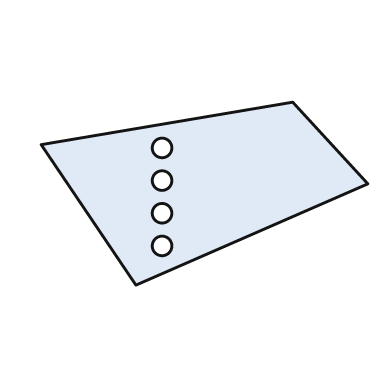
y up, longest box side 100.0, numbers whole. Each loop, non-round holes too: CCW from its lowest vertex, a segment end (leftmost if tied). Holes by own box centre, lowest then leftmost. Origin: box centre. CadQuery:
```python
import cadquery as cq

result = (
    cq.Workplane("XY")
    .moveTo(-21.0, -28.0)
    .lineTo(50.0, 3.0)
    .lineTo(27.0, 28.0)
    .lineTo(-50.0, 15.0)
    .close()
    .moveTo(-13.0, -16.0)
    .circle(3.0)
    .moveTo(-13.0, -6.0)
    .circle(3.0)
    .moveTo(-13.0, 4.0)
    .circle(3.0)
    .moveTo(-13.0, 14.0)
    .circle(3.0)
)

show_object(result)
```